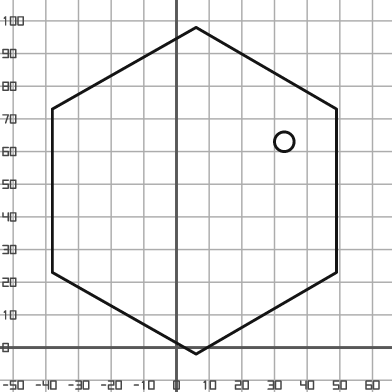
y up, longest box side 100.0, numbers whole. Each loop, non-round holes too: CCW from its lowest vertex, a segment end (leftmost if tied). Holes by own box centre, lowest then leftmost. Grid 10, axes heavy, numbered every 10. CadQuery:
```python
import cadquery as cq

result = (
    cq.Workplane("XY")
    .moveTo(6.0, -2.0)
    .lineTo(49.0, 23.0)
    .lineTo(49.0, 73.0)
    .lineTo(6.0, 98.0)
    .lineTo(-38.0, 73.0)
    .lineTo(-38.0, 23.0)
    .close()
    .moveTo(33.0, 63.0)
    .circle(3.0)
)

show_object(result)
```